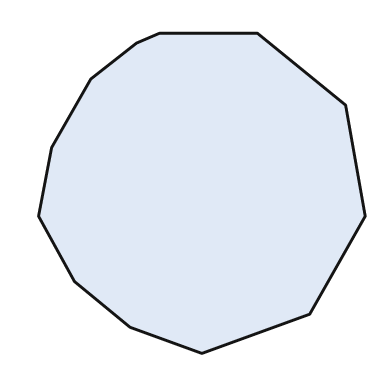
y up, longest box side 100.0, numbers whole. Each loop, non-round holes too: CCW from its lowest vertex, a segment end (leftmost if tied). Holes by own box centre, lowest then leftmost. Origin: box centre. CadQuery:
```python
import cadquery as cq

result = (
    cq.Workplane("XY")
    .moveTo(0.0, -49.0)
    .lineTo(33.0, -37.0)
    .lineTo(50.0, -7.0)
    .lineTo(44.0, 27.0)
    .lineTo(17.0, 49.0)
    .lineTo(-13.0, 49.0)
    .lineTo(-20.0, 46.0)
    .lineTo(-34.0, 35.0)
    .lineTo(-46.0, 14.0)
    .lineTo(-50.0, -7.0)
    .lineTo(-39.0, -27.0)
    .lineTo(-22.0, -41.0)
    .close()
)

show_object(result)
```